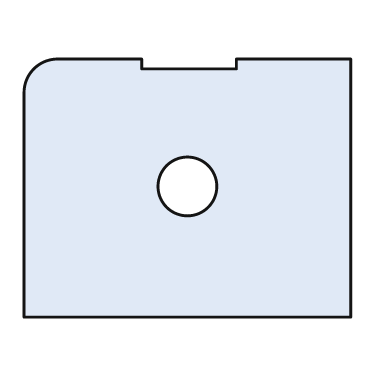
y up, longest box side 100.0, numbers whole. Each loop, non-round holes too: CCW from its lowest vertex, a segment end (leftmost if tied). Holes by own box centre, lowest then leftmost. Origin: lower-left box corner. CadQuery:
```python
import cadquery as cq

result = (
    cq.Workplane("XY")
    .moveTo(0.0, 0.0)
    .lineTo(100.0, 0.0)
    .lineTo(100.0, 79.0)
    .lineTo(65.0, 79.0)
    .lineTo(65.0, 76.0)
    .lineTo(36.0, 76.0)
    .lineTo(36.0, 79.0)
    .lineTo(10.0, 79.0)
    .threePointArc((3.0, 76.0), (0.0, 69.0))
    .close()
    .moveTo(50.0, 40.0)
    .circle(9.0)
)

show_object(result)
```